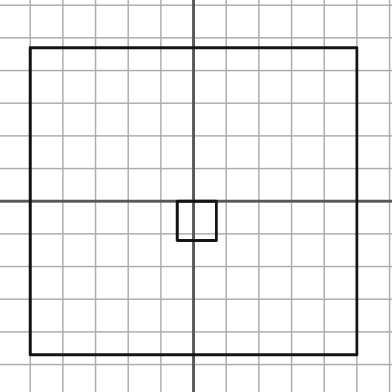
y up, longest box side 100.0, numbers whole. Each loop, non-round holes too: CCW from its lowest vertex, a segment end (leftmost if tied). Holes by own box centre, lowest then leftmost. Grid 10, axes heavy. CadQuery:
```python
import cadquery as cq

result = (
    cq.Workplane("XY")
    .moveTo(-50.0, -47.0)
    .lineTo(50.0, -47.0)
    .lineTo(50.0, 47.0)
    .lineTo(-50.0, 47.0)
    .close()
    .moveTo(-5.0, -12.0)
    .lineTo(7.0, -12.0)
    .lineTo(7.0, 0.0)
    .lineTo(-5.0, 0.0)
    .close()
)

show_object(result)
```